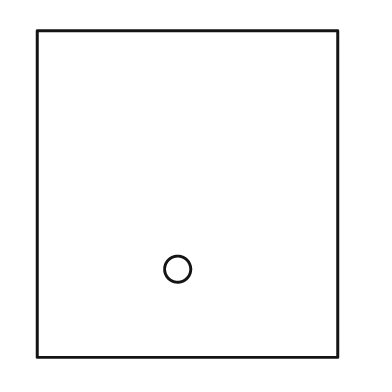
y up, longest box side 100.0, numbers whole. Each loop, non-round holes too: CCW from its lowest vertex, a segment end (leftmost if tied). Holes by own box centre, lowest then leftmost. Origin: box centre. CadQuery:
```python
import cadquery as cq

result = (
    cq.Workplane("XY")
    .moveTo(-46.0, -50.0)
    .lineTo(46.0, -50.0)
    .lineTo(46.0, 50.0)
    .lineTo(-46.0, 50.0)
    .close()
    .moveTo(-3.0, -23.0)
    .circle(4.0)
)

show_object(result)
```